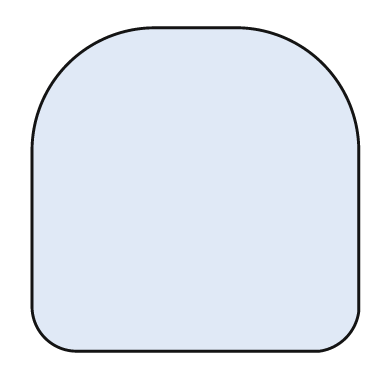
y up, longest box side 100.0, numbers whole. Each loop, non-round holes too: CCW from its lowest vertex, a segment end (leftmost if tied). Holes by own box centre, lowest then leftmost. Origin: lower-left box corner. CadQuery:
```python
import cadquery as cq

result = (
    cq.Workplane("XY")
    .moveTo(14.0, 0.0)
    .lineTo(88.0, 0.0)
    .threePointArc((96.0, 4.0), (100.0, 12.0))
    .lineTo(100.0, 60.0)
    .threePointArc((89.0, 88.0), (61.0, 99.0))
    .lineTo(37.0, 99.0)
    .threePointArc((11.0, 88.0), (0.0, 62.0))
    .lineTo(0.0, 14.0)
    .threePointArc((4.0, 4.0), (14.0, 0.0))
    .close()
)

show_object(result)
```